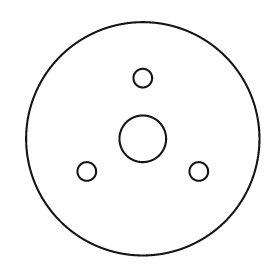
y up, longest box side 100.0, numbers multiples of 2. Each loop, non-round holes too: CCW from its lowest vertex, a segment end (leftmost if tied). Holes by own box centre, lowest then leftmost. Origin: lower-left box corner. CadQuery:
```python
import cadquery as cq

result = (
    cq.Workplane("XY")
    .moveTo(50.0, 50.0)
    .circle(50.0)
    .moveTo(26.0, 36.0)
    .circle(4.0)
    .moveTo(74.0, 36.0)
    .circle(4.0)
    .moveTo(50.0, 50.0)
    .circle(10.0)
    .moveTo(50.0, 76.0)
    .circle(4.0)
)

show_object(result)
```